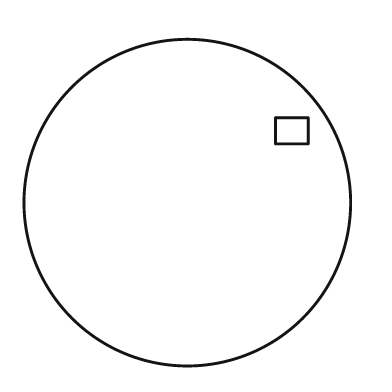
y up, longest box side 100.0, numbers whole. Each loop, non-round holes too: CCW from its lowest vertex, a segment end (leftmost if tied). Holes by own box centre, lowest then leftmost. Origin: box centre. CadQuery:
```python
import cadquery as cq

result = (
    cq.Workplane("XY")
    .moveTo(0.0, 0.0)
    .circle(50.0)
    .moveTo(27.0, 18.0)
    .lineTo(37.0, 18.0)
    .lineTo(37.0, 26.0)
    .lineTo(27.0, 26.0)
    .close()
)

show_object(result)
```